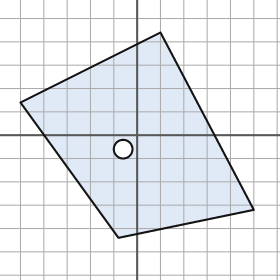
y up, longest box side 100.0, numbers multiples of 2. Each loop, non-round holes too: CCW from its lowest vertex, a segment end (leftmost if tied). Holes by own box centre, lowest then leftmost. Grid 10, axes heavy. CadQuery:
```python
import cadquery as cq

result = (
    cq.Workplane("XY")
    .moveTo(-8.0, -44.0)
    .lineTo(50.0, -32.0)
    .lineTo(10.0, 44.0)
    .lineTo(-50.0, 14.0)
    .close()
    .moveTo(-6.0, -6.0)
    .circle(4.0)
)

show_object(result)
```